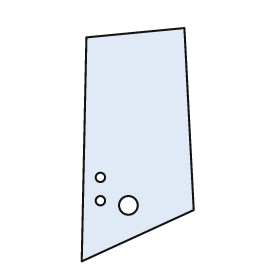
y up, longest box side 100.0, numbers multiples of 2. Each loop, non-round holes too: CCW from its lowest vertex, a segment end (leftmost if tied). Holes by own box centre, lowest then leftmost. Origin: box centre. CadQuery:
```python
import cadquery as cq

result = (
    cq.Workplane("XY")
    .moveTo(-24.0, -50.0)
    .lineTo(24.0, -28.0)
    .lineTo(20.0, 50.0)
    .lineTo(-22.0, 46.0)
    .close()
    .moveTo(-4.0, -26.0)
    .circle(4.0)
    .moveTo(-16.0, -24.0)
    .circle(2.0)
    .moveTo(-16.0, -14.0)
    .circle(2.0)
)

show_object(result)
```